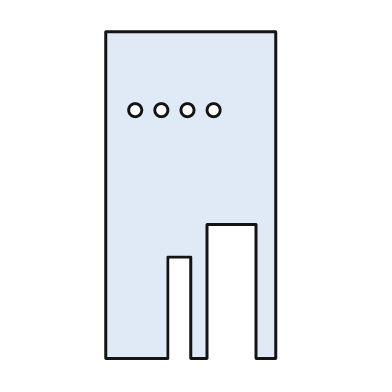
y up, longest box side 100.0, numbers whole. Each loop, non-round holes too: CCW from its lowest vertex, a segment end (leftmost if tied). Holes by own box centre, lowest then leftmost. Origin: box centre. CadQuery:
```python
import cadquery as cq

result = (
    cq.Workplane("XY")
    .moveTo(-26.0, -50.0)
    .lineTo(-7.0, -50.0)
    .lineTo(-7.0, -19.0)
    .lineTo(0.0, -19.0)
    .lineTo(0.0, -50.0)
    .lineTo(5.0, -50.0)
    .lineTo(5.0, -9.0)
    .lineTo(20.0, -9.0)
    .lineTo(20.0, -50.0)
    .lineTo(26.0, -50.0)
    .lineTo(26.0, 50.0)
    .lineTo(-26.0, 50.0)
    .close()
    .moveTo(-17.0, 26.0)
    .circle(2.0)
    .moveTo(-9.0, 26.0)
    .circle(2.0)
    .moveTo(-1.0, 26.0)
    .circle(2.0)
    .moveTo(7.0, 26.0)
    .circle(2.0)
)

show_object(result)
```